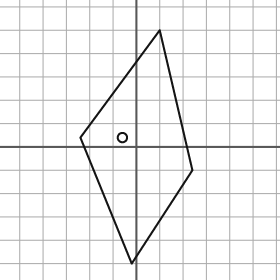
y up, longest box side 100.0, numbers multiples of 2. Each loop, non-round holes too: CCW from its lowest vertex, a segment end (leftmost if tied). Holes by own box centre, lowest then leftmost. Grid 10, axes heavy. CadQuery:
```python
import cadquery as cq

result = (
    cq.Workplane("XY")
    .moveTo(-2.0, -50.0)
    .lineTo(24.0, -10.0)
    .lineTo(10.0, 50.0)
    .lineTo(-24.0, 4.0)
    .close()
    .moveTo(-6.0, 4.0)
    .circle(2.0)
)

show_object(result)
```